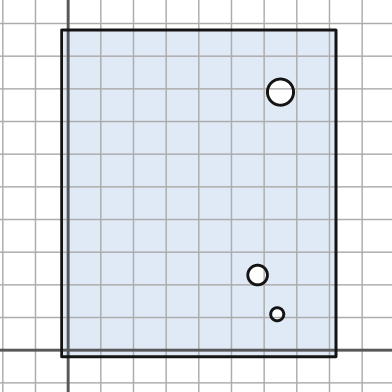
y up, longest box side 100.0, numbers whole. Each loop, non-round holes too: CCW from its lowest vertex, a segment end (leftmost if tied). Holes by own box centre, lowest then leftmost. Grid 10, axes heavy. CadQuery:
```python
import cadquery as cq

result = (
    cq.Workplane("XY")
    .moveTo(-2.0, -2.0)
    .lineTo(82.0, -2.0)
    .lineTo(82.0, 98.0)
    .lineTo(-2.0, 98.0)
    .close()
    .moveTo(64.0, 11.0)
    .circle(2.0)
    .moveTo(58.0, 23.0)
    .circle(3.0)
    .moveTo(65.0, 79.0)
    .circle(4.0)
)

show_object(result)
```